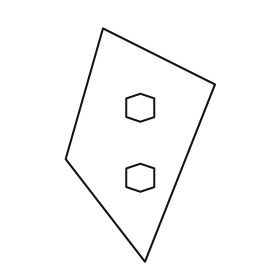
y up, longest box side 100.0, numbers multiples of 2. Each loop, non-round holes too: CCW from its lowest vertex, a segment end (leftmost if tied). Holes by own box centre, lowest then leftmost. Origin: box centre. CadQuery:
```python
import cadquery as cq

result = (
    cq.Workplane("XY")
    .moveTo(2.0, -50.0)
    .lineTo(32.0, 26.0)
    .lineTo(-16.0, 50.0)
    .lineTo(-32.0, -6.0)
    .close()
    .moveTo(0.0, -20.0)
    .lineTo(6.0, -18.0)
    .lineTo(6.0, -10.0)
    .lineTo(0.0, -8.0)
    .lineTo(-6.0, -10.0)
    .lineTo(-6.0, -18.0)
    .close()
    .moveTo(0.0, 10.0)
    .lineTo(6.0, 12.0)
    .lineTo(6.0, 20.0)
    .lineTo(0.0, 22.0)
    .lineTo(-6.0, 20.0)
    .lineTo(-6.0, 12.0)
    .close()
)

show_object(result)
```